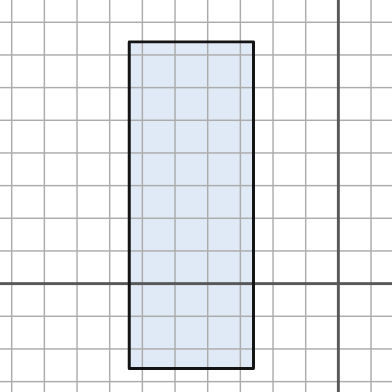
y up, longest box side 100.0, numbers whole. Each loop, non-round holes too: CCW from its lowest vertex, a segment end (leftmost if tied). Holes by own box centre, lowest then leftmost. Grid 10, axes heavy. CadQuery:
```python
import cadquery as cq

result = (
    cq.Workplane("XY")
    .moveTo(-64.0, -26.0)
    .lineTo(-26.0, -26.0)
    .lineTo(-26.0, 74.0)
    .lineTo(-64.0, 74.0)
    .close()
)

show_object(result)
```